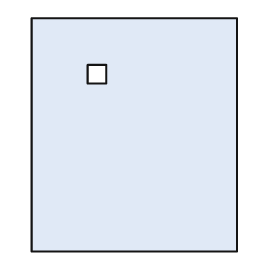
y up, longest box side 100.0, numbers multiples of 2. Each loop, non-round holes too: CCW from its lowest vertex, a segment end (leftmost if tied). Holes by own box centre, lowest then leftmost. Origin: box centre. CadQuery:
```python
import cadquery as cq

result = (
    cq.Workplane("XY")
    .moveTo(-44.0, -50.0)
    .lineTo(44.0, -50.0)
    .lineTo(44.0, 50.0)
    .lineTo(-44.0, 50.0)
    .close()
    .moveTo(-20.0, 22.0)
    .lineTo(-12.0, 22.0)
    .lineTo(-12.0, 30.0)
    .lineTo(-20.0, 30.0)
    .close()
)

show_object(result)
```